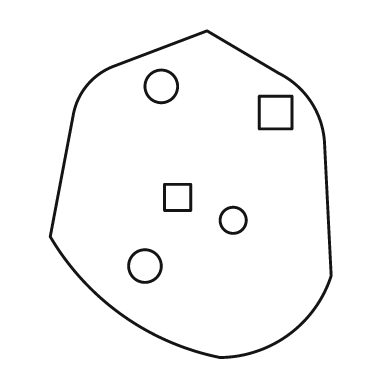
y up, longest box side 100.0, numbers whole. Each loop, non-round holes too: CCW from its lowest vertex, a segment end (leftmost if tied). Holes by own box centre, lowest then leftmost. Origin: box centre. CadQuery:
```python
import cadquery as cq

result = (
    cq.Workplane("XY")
    .moveTo(9.0, -50.0)
    .threePointArc((30.0, -43.0), (43.0, -25.0))
    .lineTo(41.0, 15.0)
    .threePointArc((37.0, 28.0), (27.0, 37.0))
    .lineTo(5.0, 50.0)
    .lineTo(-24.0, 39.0)
    .threePointArc((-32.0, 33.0), (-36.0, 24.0))
    .lineTo(-43.0, -13.0)
    .threePointArc((-21.0, -37.0), (9.0, -50.0))
    .close()
    .moveTo(-14.0, -22.0)
    .circle(5.0)
    .moveTo(13.0, -8.0)
    .circle(4.0)
    .moveTo(-8.0, -5.0)
    .lineTo(0.0, -5.0)
    .lineTo(0.0, 3.0)
    .lineTo(-8.0, 3.0)
    .close()
    .moveTo(21.0, 20.0)
    .lineTo(31.0, 20.0)
    .lineTo(31.0, 30.0)
    .lineTo(21.0, 30.0)
    .close()
    .moveTo(-9.0, 33.0)
    .circle(5.0)
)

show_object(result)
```